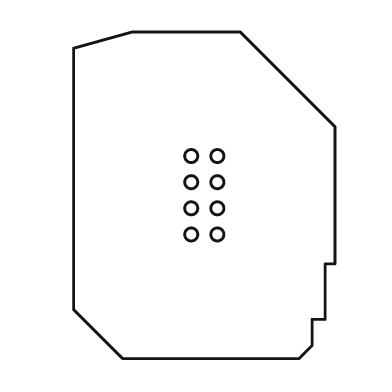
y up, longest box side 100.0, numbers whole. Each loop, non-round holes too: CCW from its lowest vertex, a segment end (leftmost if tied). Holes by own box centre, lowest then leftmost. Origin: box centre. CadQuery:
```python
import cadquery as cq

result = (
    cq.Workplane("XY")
    .moveTo(-25.0, -50.0)
    .lineTo(29.0, -50.0)
    .lineTo(33.0, -46.0)
    .lineTo(33.0, -38.0)
    .lineTo(37.0, -38.0)
    .lineTo(37.0, -21.0)
    .lineTo(40.0, -21.0)
    .lineTo(40.0, 21.0)
    .lineTo(11.0, 50.0)
    .lineTo(-22.0, 50.0)
    .lineTo(-40.0, 45.0)
    .lineTo(-40.0, -35.0)
    .close()
    .moveTo(-4.0, -12.0)
    .circle(2.0)
    .moveTo(4.0, -12.0)
    .circle(2.0)
    .moveTo(-4.0, -4.0)
    .circle(2.0)
    .moveTo(4.0, -4.0)
    .circle(2.0)
    .moveTo(-4.0, 4.0)
    .circle(2.0)
    .moveTo(4.0, 4.0)
    .circle(2.0)
    .moveTo(-4.0, 12.0)
    .circle(2.0)
    .moveTo(4.0, 12.0)
    .circle(2.0)
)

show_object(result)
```